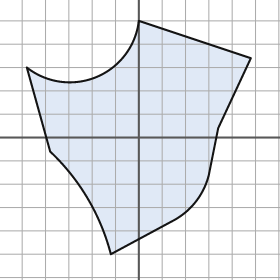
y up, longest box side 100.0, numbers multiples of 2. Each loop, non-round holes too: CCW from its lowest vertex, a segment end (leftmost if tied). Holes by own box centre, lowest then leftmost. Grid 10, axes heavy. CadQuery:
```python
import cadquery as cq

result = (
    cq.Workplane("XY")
    .moveTo(-12.0, -50.0)
    .lineTo(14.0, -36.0)
    .threePointArc((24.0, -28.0), (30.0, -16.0))
    .lineTo(34.0, 4.0)
    .lineTo(48.0, 34.0)
    .lineTo(0.0, 50.0)
    .threePointArc((-18.0, 26.0), (-48.0, 30.0))
    .lineTo(-38.0, -6.0)
    .threePointArc((-22.0, -26.0), (-12.0, -50.0))
    .close()
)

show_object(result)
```